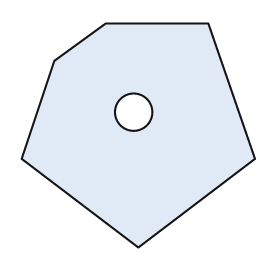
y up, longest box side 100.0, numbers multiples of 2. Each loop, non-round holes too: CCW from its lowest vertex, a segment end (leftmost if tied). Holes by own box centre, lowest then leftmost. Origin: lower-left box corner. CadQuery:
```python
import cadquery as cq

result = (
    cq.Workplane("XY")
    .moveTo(50.0, 0.0)
    .lineTo(100.0, 38.0)
    .lineTo(80.0, 96.0)
    .lineTo(36.0, 96.0)
    .lineTo(14.0, 80.0)
    .lineTo(0.0, 38.0)
    .close()
    .moveTo(48.0, 58.0)
    .circle(8.0)
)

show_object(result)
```